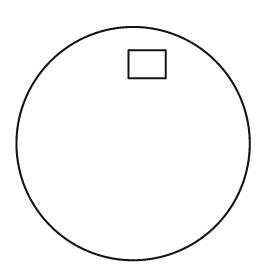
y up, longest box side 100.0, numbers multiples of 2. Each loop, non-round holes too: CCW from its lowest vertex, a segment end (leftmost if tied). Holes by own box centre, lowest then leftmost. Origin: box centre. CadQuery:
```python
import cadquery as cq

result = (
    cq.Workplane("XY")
    .moveTo(0.0, 0.0)
    .circle(50.0)
    .moveTo(-2.0, 28.0)
    .lineTo(14.0, 28.0)
    .lineTo(14.0, 40.0)
    .lineTo(-2.0, 40.0)
    .close()
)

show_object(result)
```